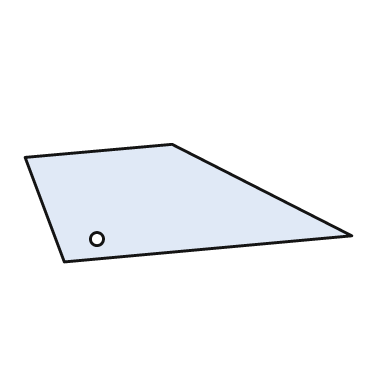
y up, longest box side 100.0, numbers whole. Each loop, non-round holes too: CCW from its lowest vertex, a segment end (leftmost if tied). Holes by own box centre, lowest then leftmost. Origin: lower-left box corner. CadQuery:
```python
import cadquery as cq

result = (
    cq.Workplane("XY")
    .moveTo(12.0, 0.0)
    .lineTo(100.0, 8.0)
    .lineTo(45.0, 36.0)
    .lineTo(0.0, 32.0)
    .close()
    .moveTo(22.0, 7.0)
    .circle(2.0)
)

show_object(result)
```